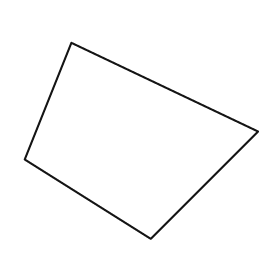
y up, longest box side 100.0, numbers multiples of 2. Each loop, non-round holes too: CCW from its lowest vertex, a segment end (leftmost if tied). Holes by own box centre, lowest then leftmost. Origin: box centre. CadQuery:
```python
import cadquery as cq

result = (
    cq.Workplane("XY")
    .moveTo(4.0, -42.0)
    .lineTo(50.0, 4.0)
    .lineTo(-30.0, 42.0)
    .lineTo(-50.0, -8.0)
    .close()
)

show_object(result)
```